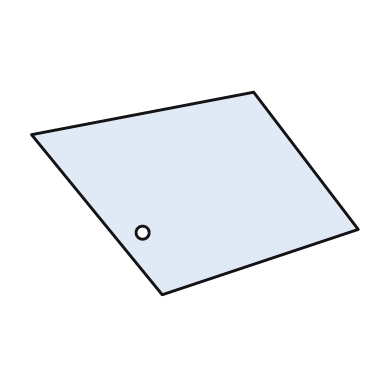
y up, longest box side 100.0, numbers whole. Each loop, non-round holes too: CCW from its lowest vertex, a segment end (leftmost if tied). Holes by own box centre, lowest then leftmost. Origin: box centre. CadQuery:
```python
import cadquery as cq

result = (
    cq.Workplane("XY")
    .moveTo(-10.0, -31.0)
    .lineTo(50.0, -11.0)
    .lineTo(18.0, 31.0)
    .lineTo(-50.0, 18.0)
    .close()
    .moveTo(-16.0, -12.0)
    .circle(2.0)
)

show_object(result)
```